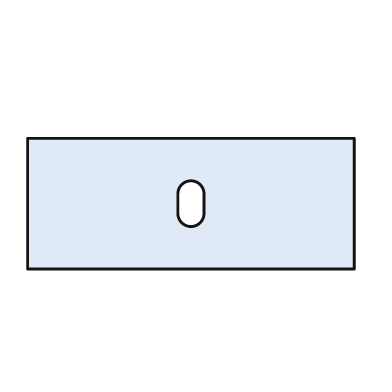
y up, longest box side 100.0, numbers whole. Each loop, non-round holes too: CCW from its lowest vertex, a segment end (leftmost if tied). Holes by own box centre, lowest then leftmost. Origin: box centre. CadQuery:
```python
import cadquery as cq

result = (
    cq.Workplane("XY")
    .moveTo(-50.0, -20.0)
    .lineTo(50.0, -20.0)
    .lineTo(50.0, 20.0)
    .lineTo(-50.0, 20.0)
    .close()
    .moveTo(-4.0, -3.0)
    .threePointArc((0.0, -7.0), (4.0, -3.0))
    .lineTo(4.0, 3.0)
    .threePointArc((0.0, 7.0), (-4.0, 3.0))
    .close()
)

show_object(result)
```